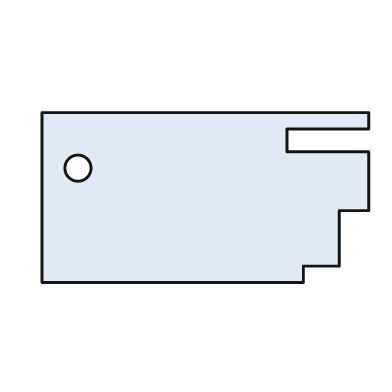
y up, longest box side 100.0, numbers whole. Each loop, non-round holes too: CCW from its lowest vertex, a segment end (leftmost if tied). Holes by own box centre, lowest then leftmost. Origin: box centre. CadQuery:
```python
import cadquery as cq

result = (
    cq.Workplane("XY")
    .moveTo(-50.0, -26.0)
    .lineTo(30.0, -26.0)
    .lineTo(30.0, -21.0)
    .lineTo(41.0, -21.0)
    .lineTo(41.0, -4.0)
    .lineTo(50.0, -4.0)
    .lineTo(50.0, 14.0)
    .lineTo(25.0, 14.0)
    .lineTo(25.0, 21.0)
    .lineTo(50.0, 21.0)
    .lineTo(50.0, 26.0)
    .lineTo(-50.0, 26.0)
    .close()
    .moveTo(-39.0, 9.0)
    .circle(4.0)
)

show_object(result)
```